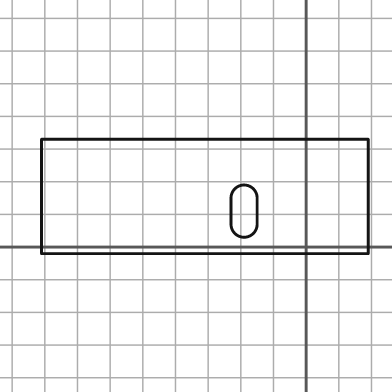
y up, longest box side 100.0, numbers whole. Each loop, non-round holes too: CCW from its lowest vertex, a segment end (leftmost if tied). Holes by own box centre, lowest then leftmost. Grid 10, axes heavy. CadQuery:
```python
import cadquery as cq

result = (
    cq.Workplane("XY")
    .moveTo(-81.0, -2.0)
    .lineTo(19.0, -2.0)
    .lineTo(19.0, 33.0)
    .lineTo(-81.0, 33.0)
    .close()
    .moveTo(-23.0, 7.0)
    .threePointArc((-19.0, 3.0), (-15.0, 7.0))
    .lineTo(-15.0, 15.0)
    .threePointArc((-19.0, 19.0), (-23.0, 15.0))
    .close()
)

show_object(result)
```